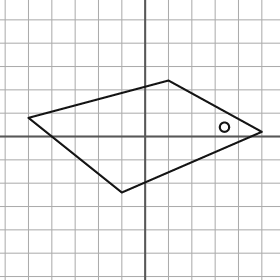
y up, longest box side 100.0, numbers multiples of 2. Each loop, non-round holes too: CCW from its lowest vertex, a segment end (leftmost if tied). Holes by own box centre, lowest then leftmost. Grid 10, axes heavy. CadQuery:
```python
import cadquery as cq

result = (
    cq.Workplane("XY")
    .moveTo(-10.0, -24.0)
    .lineTo(50.0, 2.0)
    .lineTo(10.0, 24.0)
    .lineTo(-50.0, 8.0)
    .close()
    .moveTo(34.0, 4.0)
    .circle(2.0)
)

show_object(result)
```